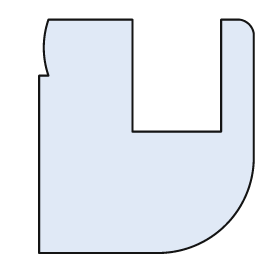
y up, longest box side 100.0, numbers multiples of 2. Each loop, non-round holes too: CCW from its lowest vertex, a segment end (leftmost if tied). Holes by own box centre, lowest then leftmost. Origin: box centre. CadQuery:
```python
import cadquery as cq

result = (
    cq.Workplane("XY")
    .moveTo(-46.0, -50.0)
    .lineTo(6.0, -50.0)
    .threePointArc((34.0, -38.0), (46.0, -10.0))
    .lineTo(46.0, 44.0)
    .threePointArc((44.0, 48.0), (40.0, 50.0))
    .lineTo(32.0, 50.0)
    .lineTo(32.0, 2.0)
    .lineTo(-6.0, 2.0)
    .lineTo(-6.0, 50.0)
    .lineTo(-42.0, 50.0)
    .threePointArc((-44.0, 38.0), (-42.0, 26.0))
    .lineTo(-46.0, 26.0)
    .close()
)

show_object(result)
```